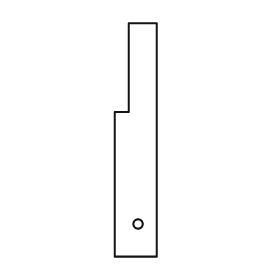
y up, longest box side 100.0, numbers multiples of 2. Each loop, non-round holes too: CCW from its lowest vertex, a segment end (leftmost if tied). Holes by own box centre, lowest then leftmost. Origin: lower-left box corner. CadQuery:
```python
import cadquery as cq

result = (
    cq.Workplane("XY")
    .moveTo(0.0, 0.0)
    .lineTo(18.0, 0.0)
    .lineTo(18.0, 100.0)
    .lineTo(6.0, 100.0)
    .lineTo(6.0, 62.0)
    .lineTo(0.0, 62.0)
    .close()
    .moveTo(10.0, 14.0)
    .circle(2.0)
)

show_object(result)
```